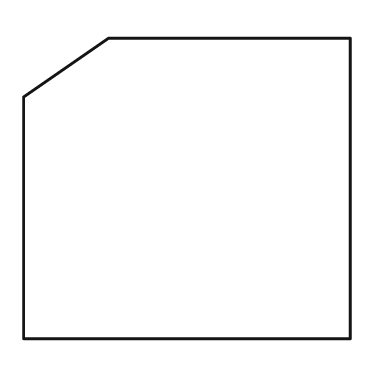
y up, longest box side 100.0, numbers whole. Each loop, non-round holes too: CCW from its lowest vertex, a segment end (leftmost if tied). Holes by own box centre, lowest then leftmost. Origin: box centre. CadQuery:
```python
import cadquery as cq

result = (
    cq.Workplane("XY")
    .moveTo(-50.0, -46.0)
    .lineTo(50.0, -46.0)
    .lineTo(50.0, 46.0)
    .lineTo(-24.0, 46.0)
    .lineTo(-50.0, 28.0)
    .close()
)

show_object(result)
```